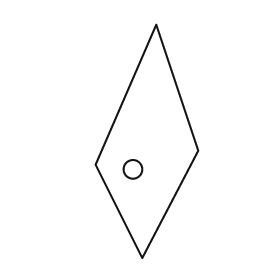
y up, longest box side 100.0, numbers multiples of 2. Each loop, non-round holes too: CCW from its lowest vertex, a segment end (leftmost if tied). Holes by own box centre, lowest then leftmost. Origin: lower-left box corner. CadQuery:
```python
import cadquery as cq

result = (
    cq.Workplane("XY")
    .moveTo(20.0, 0.0)
    .lineTo(44.0, 46.0)
    .lineTo(26.0, 100.0)
    .lineTo(0.0, 40.0)
    .close()
    .moveTo(16.0, 38.0)
    .circle(4.0)
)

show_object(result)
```